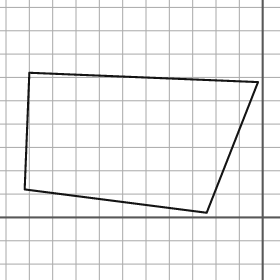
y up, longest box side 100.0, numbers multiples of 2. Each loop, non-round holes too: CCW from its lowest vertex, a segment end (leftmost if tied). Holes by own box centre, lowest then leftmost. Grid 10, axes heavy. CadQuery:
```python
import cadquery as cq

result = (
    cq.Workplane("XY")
    .moveTo(-24.0, 2.0)
    .lineTo(-2.0, 58.0)
    .lineTo(-100.0, 62.0)
    .lineTo(-102.0, 12.0)
    .close()
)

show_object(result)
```